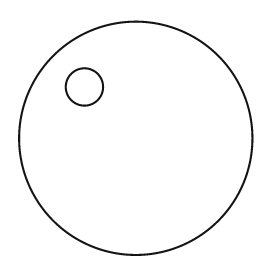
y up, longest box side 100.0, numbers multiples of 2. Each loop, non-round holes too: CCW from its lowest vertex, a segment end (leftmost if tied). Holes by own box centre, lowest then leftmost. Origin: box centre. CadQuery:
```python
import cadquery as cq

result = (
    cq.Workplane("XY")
    .moveTo(0.0, 0.0)
    .circle(50.0)
    .moveTo(-22.0, 22.0)
    .circle(8.0)
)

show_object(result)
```